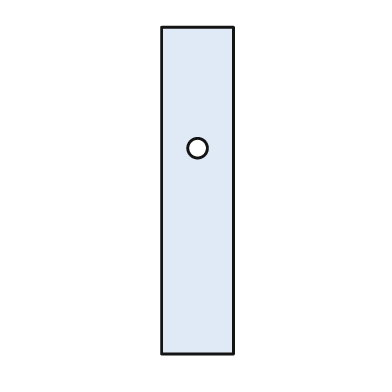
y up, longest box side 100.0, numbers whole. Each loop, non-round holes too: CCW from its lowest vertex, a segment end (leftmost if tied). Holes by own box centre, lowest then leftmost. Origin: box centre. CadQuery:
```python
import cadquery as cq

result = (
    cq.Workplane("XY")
    .moveTo(-11.0, -50.0)
    .lineTo(11.0, -50.0)
    .lineTo(11.0, 50.0)
    .lineTo(-11.0, 50.0)
    .close()
    .moveTo(0.0, 13.0)
    .circle(3.0)
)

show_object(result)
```